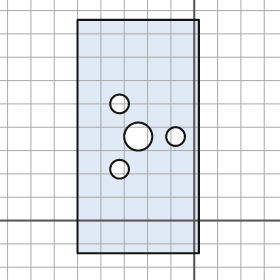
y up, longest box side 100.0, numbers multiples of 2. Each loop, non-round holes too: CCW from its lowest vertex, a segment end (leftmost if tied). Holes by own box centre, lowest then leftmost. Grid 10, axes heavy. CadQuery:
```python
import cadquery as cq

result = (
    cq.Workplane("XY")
    .moveTo(-50.0, -14.0)
    .lineTo(2.0, -14.0)
    .lineTo(2.0, 86.0)
    .lineTo(-50.0, 86.0)
    .close()
    .moveTo(-32.0, 22.0)
    .circle(4.0)
    .moveTo(-24.0, 36.0)
    .circle(6.0)
    .moveTo(-8.0, 36.0)
    .circle(4.0)
    .moveTo(-32.0, 50.0)
    .circle(4.0)
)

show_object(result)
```